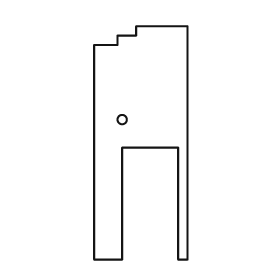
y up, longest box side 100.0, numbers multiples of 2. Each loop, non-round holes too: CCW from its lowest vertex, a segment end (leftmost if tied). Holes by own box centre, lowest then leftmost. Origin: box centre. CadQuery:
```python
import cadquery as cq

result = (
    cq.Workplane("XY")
    .moveTo(-20.0, -50.0)
    .lineTo(-8.0, -50.0)
    .lineTo(-8.0, -2.0)
    .lineTo(16.0, -2.0)
    .lineTo(16.0, -50.0)
    .lineTo(20.0, -50.0)
    .lineTo(20.0, 50.0)
    .lineTo(-2.0, 50.0)
    .lineTo(-2.0, 46.0)
    .lineTo(-10.0, 46.0)
    .lineTo(-10.0, 42.0)
    .lineTo(-20.0, 42.0)
    .close()
    .moveTo(-8.0, 10.0)
    .circle(2.0)
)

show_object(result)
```